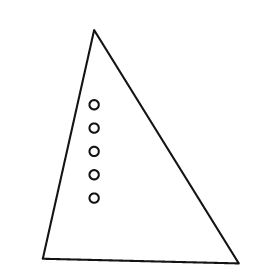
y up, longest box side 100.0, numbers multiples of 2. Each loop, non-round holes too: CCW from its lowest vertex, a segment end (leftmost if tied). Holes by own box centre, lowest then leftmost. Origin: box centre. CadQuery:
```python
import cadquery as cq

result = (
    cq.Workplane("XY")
    .moveTo(42.0, -50.0)
    .lineTo(-20.0, 50.0)
    .lineTo(-42.0, -48.0)
    .close()
    .moveTo(-20.0, -22.0)
    .circle(2.0)
    .moveTo(-20.0, -12.0)
    .circle(2.0)
    .moveTo(-20.0, -2.0)
    .circle(2.0)
    .moveTo(-20.0, 8.0)
    .circle(2.0)
    .moveTo(-20.0, 18.0)
    .circle(2.0)
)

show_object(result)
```